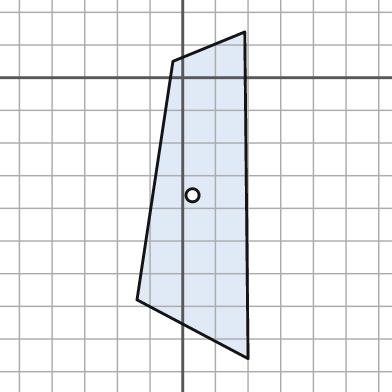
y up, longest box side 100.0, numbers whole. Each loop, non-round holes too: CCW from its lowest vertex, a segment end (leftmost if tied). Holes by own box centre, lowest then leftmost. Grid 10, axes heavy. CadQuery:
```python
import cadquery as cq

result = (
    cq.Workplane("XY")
    .moveTo(20.0, -86.0)
    .lineTo(19.0, 14.0)
    .lineTo(-3.0, 5.0)
    .lineTo(-14.0, -68.0)
    .close()
    .moveTo(3.0, -36.0)
    .circle(2.0)
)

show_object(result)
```